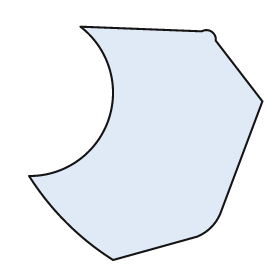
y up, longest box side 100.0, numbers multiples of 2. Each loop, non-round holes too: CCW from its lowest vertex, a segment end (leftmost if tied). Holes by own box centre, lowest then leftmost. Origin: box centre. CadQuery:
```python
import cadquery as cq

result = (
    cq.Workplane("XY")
    .moveTo(-14.0, -50.0)
    .lineTo(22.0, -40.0)
    .threePointArc((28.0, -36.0), (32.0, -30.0))
    .lineTo(50.0, 18.0)
    .lineTo(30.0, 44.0)
    .threePointArc((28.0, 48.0), (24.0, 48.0))
    .lineTo(-28.0, 50.0)
    .threePointArc((-16.0, 10.0), (-50.0, -14.0))
    .threePointArc((-34.0, -34.0), (-14.0, -50.0))
    .close()
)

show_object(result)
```